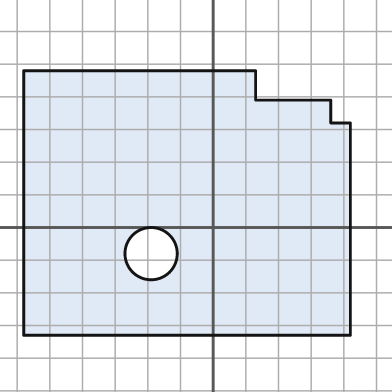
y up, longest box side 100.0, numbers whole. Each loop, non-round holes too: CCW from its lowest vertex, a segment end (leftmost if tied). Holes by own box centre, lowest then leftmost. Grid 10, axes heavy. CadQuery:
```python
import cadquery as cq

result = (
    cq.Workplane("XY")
    .moveTo(-58.0, -33.0)
    .lineTo(42.0, -33.0)
    .lineTo(42.0, 32.0)
    .lineTo(36.0, 32.0)
    .lineTo(36.0, 39.0)
    .lineTo(13.0, 39.0)
    .lineTo(13.0, 48.0)
    .lineTo(-58.0, 48.0)
    .close()
    .moveTo(-19.0, -8.0)
    .circle(8.0)
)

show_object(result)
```